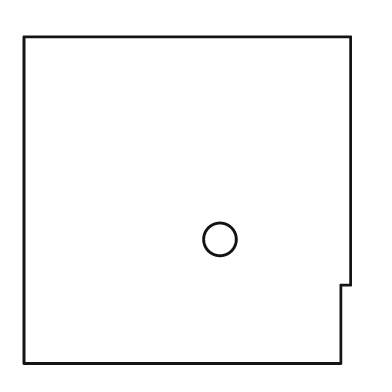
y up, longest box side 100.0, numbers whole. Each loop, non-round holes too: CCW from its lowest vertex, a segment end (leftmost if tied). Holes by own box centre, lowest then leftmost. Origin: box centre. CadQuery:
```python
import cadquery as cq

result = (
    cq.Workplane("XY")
    .moveTo(-50.0, -50.0)
    .lineTo(47.0, -50.0)
    .lineTo(47.0, -26.0)
    .lineTo(50.0, -26.0)
    .lineTo(50.0, 50.0)
    .lineTo(-50.0, 50.0)
    .close()
    .moveTo(10.0, -12.0)
    .circle(5.0)
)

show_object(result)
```